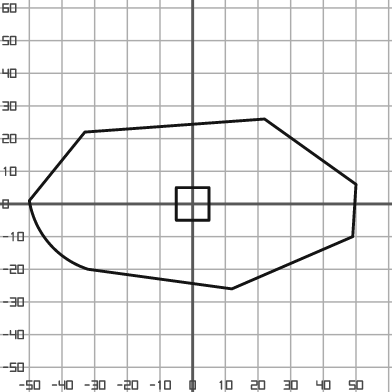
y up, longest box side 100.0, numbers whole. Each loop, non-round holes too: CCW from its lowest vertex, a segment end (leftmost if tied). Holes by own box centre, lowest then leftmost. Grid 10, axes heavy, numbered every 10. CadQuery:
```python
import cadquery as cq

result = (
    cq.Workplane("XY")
    .moveTo(12.0, -26.0)
    .lineTo(49.0, -10.0)
    .lineTo(50.0, 6.0)
    .lineTo(22.0, 26.0)
    .lineTo(-33.0, 22.0)
    .lineTo(-50.0, 1.0)
    .threePointArc((-44.0, -12.0), (-32.0, -20.0))
    .close()
    .moveTo(-5.0, -5.0)
    .lineTo(5.0, -5.0)
    .lineTo(5.0, 5.0)
    .lineTo(-5.0, 5.0)
    .close()
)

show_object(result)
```